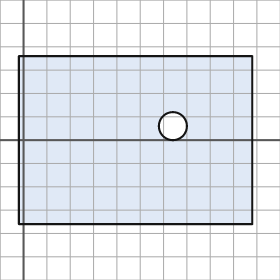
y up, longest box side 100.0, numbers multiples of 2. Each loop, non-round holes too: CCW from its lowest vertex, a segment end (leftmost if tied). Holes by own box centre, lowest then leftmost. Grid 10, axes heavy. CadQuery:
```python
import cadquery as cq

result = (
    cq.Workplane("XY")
    .moveTo(-2.0, -36.0)
    .lineTo(98.0, -36.0)
    .lineTo(98.0, 36.0)
    .lineTo(-2.0, 36.0)
    .close()
    .moveTo(64.0, 6.0)
    .circle(6.0)
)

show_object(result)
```